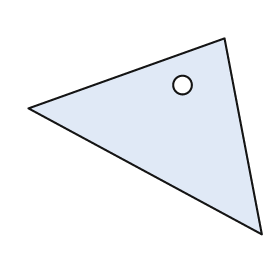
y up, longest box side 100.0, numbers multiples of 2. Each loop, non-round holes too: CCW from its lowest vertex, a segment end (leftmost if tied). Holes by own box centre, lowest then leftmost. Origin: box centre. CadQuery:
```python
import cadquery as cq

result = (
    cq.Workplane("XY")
    .moveTo(50.0, -42.0)
    .lineTo(34.0, 42.0)
    .lineTo(-50.0, 12.0)
    .close()
    .moveTo(16.0, 22.0)
    .circle(4.0)
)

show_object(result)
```